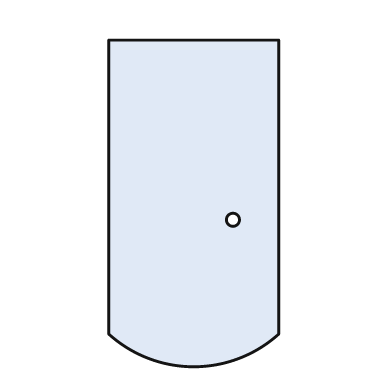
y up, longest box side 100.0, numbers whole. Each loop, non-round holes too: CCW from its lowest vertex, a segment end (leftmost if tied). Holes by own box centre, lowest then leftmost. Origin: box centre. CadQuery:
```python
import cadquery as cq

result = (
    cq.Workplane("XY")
    .moveTo(-26.0, -40.0)
    .threePointArc((0.0, -50.0), (26.0, -40.0))
    .lineTo(26.0, 50.0)
    .lineTo(-26.0, 50.0)
    .close()
    .moveTo(12.0, -5.0)
    .circle(2.0)
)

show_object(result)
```